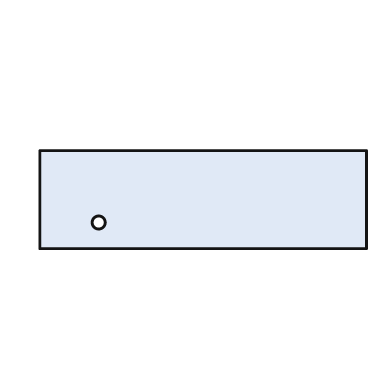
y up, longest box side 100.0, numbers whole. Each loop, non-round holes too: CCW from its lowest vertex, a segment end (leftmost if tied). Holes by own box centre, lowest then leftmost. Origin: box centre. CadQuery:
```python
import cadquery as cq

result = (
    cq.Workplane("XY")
    .moveTo(-50.0, -15.0)
    .lineTo(50.0, -15.0)
    .lineTo(50.0, 15.0)
    .lineTo(-50.0, 15.0)
    .close()
    .moveTo(-32.0, -7.0)
    .circle(2.0)
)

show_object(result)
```